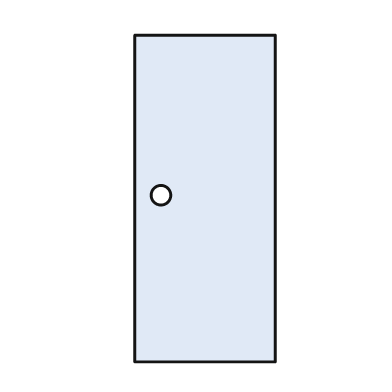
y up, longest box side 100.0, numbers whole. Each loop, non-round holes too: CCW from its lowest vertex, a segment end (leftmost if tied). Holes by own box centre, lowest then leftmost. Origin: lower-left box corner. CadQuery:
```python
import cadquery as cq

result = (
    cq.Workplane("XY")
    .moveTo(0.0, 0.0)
    .lineTo(43.0, 0.0)
    .lineTo(43.0, 100.0)
    .lineTo(0.0, 100.0)
    .close()
    .moveTo(8.0, 51.0)
    .circle(3.0)
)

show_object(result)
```